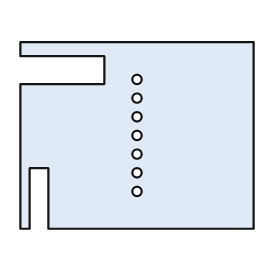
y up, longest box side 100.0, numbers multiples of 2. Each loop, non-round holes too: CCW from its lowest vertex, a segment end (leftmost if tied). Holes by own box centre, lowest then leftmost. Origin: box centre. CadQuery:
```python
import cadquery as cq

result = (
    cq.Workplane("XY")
    .moveTo(-50.0, -40.0)
    .lineTo(-46.0, -40.0)
    .lineTo(-46.0, -14.0)
    .lineTo(-38.0, -14.0)
    .lineTo(-38.0, -40.0)
    .lineTo(50.0, -40.0)
    .lineTo(50.0, 40.0)
    .lineTo(-50.0, 40.0)
    .lineTo(-50.0, 34.0)
    .lineTo(-14.0, 34.0)
    .lineTo(-14.0, 22.0)
    .lineTo(-50.0, 22.0)
    .close()
    .moveTo(0.0, -24.0)
    .circle(2.0)
    .moveTo(0.0, -16.0)
    .circle(2.0)
    .moveTo(0.0, -8.0)
    .circle(2.0)
    .moveTo(0.0, 0.0)
    .circle(2.0)
    .moveTo(0.0, 8.0)
    .circle(2.0)
    .moveTo(0.0, 16.0)
    .circle(2.0)
    .moveTo(0.0, 24.0)
    .circle(2.0)
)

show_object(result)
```